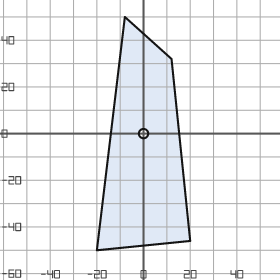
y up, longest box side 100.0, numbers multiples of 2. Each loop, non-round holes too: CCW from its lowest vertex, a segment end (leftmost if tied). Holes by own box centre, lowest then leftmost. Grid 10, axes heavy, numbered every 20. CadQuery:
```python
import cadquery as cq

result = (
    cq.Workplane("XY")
    .moveTo(-20.0, -50.0)
    .lineTo(20.0, -46.0)
    .lineTo(12.0, 32.0)
    .lineTo(-8.0, 50.0)
    .close()
    .moveTo(0.0, 0.0)
    .circle(2.0)
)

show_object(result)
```